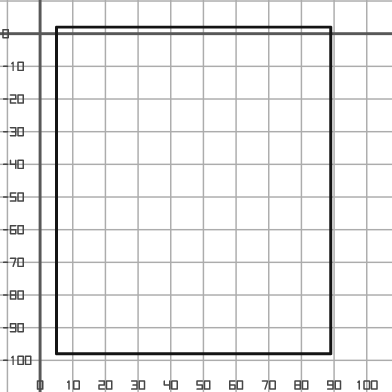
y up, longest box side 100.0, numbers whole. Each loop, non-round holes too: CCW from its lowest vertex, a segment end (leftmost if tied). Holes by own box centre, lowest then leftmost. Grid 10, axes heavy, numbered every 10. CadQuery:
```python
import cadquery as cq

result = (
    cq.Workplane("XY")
    .moveTo(5.0, -98.0)
    .lineTo(89.0, -98.0)
    .lineTo(89.0, 2.0)
    .lineTo(5.0, 2.0)
    .close()
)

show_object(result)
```